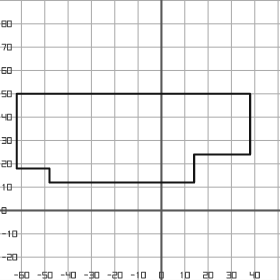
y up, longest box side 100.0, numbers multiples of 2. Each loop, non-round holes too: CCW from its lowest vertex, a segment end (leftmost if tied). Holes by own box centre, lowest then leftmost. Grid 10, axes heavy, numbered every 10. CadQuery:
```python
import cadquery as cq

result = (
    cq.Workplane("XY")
    .moveTo(-48.0, 12.0)
    .lineTo(14.0, 12.0)
    .lineTo(14.0, 24.0)
    .lineTo(38.0, 24.0)
    .lineTo(38.0, 50.0)
    .lineTo(-62.0, 50.0)
    .lineTo(-62.0, 18.0)
    .lineTo(-48.0, 18.0)
    .close()
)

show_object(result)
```